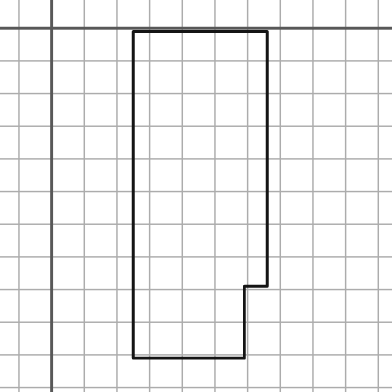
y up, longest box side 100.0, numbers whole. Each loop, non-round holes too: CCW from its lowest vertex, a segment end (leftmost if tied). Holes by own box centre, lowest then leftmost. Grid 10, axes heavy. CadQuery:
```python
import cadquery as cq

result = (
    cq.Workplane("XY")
    .moveTo(25.0, -101.0)
    .lineTo(59.0, -101.0)
    .lineTo(59.0, -79.0)
    .lineTo(66.0, -79.0)
    .lineTo(66.0, -1.0)
    .lineTo(25.0, -1.0)
    .close()
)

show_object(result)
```